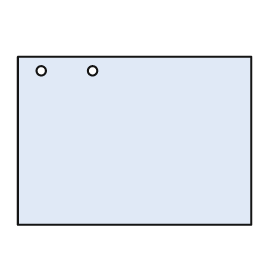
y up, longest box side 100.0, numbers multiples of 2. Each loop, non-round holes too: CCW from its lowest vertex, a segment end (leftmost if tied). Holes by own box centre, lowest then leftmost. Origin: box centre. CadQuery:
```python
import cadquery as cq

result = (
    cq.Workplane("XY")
    .moveTo(-50.0, -36.0)
    .lineTo(50.0, -36.0)
    .lineTo(50.0, 36.0)
    .lineTo(-50.0, 36.0)
    .close()
    .moveTo(-40.0, 30.0)
    .circle(2.0)
    .moveTo(-18.0, 30.0)
    .circle(2.0)
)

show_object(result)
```